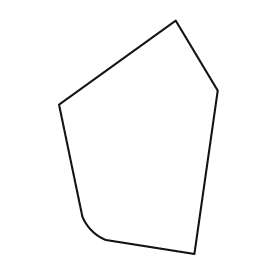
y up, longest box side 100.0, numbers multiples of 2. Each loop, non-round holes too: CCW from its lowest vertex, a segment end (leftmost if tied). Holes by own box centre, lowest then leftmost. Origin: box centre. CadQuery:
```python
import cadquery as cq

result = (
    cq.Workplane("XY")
    .moveTo(24.0, -50.0)
    .lineTo(34.0, 20.0)
    .lineTo(16.0, 50.0)
    .lineTo(-34.0, 14.0)
    .lineTo(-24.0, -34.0)
    .threePointArc((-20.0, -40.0), (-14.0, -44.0))
    .close()
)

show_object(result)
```